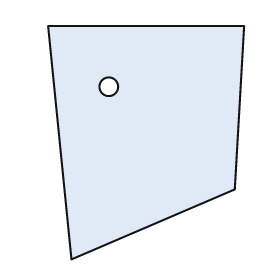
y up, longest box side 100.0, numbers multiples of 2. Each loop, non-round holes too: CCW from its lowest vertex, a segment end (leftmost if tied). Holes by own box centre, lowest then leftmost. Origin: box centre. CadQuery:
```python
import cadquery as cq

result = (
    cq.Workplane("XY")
    .moveTo(-32.0, -50.0)
    .lineTo(38.0, -20.0)
    .lineTo(42.0, 50.0)
    .lineTo(-42.0, 50.0)
    .close()
    .moveTo(-16.0, 24.0)
    .circle(4.0)
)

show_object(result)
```